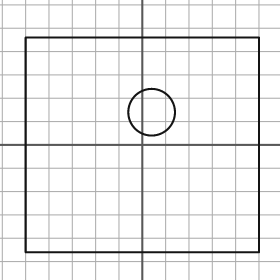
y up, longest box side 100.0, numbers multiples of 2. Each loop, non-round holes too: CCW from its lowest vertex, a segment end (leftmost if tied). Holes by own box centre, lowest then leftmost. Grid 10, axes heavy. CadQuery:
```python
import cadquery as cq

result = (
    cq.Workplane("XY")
    .moveTo(-50.0, -46.0)
    .lineTo(50.0, -46.0)
    .lineTo(50.0, 46.0)
    .lineTo(-50.0, 46.0)
    .close()
    .moveTo(4.0, 14.0)
    .circle(10.0)
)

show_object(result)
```